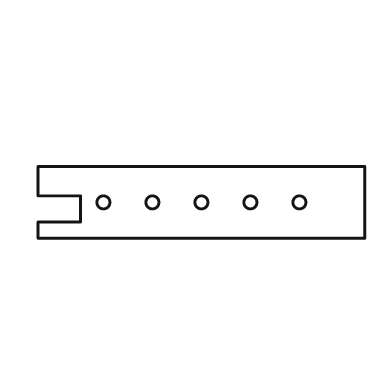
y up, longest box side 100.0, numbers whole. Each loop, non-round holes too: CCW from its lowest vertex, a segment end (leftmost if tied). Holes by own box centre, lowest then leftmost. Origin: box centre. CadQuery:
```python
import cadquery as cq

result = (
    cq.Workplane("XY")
    .moveTo(-50.0, -11.0)
    .lineTo(50.0, -11.0)
    .lineTo(50.0, 11.0)
    .lineTo(-50.0, 11.0)
    .lineTo(-50.0, 2.0)
    .lineTo(-37.0, 2.0)
    .lineTo(-37.0, -6.0)
    .lineTo(-50.0, -6.0)
    .close()
    .moveTo(-30.0, 0.0)
    .circle(2.0)
    .moveTo(-15.0, 0.0)
    .circle(2.0)
    .moveTo(0.0, 0.0)
    .circle(2.0)
    .moveTo(15.0, 0.0)
    .circle(2.0)
    .moveTo(30.0, 0.0)
    .circle(2.0)
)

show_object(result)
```